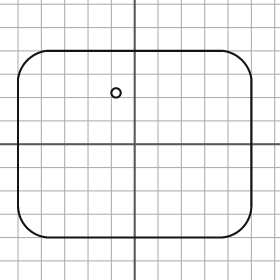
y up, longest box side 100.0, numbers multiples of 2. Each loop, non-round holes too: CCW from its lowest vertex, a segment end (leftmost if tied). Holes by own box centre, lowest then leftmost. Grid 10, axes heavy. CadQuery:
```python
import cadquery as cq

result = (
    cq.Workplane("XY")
    .moveTo(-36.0, -40.0)
    .lineTo(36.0, -40.0)
    .threePointArc((46.0, -36.0), (50.0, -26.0))
    .lineTo(50.0, 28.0)
    .threePointArc((46.0, 36.0), (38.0, 40.0))
    .lineTo(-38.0, 40.0)
    .threePointArc((-46.0, 36.0), (-50.0, 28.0))
    .lineTo(-50.0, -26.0)
    .threePointArc((-46.0, -36.0), (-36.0, -40.0))
    .close()
    .moveTo(-8.0, 22.0)
    .circle(2.0)
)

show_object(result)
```